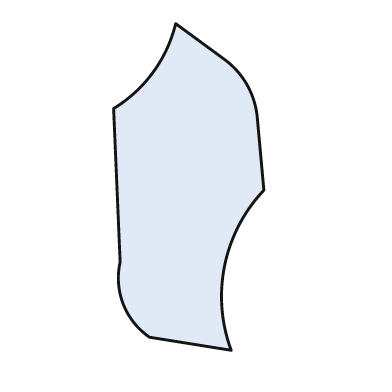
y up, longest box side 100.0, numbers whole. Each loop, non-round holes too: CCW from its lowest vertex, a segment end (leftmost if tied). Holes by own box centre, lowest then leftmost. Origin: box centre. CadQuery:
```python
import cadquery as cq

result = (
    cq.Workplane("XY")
    .moveTo(13.0, -50.0)
    .threePointArc((11.0, -24.0), (23.0, -1.0))
    .lineTo(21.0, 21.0)
    .threePointArc((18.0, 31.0), (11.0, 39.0))
    .lineTo(-4.0, 50.0)
    .threePointArc((-11.0, 35.0), (-23.0, 24.0))
    .lineTo(-21.0, -23.0)
    .threePointArc((-20.0, -36.0), (-12.0, -46.0))
    .close()
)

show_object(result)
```